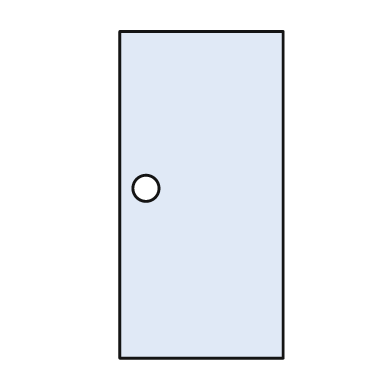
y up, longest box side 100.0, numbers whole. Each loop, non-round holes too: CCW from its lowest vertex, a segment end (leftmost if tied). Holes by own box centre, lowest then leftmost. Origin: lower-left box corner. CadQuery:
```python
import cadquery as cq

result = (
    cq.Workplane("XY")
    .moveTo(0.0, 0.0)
    .lineTo(50.0, 0.0)
    .lineTo(50.0, 100.0)
    .lineTo(0.0, 100.0)
    .close()
    .moveTo(8.0, 52.0)
    .circle(4.0)
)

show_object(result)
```